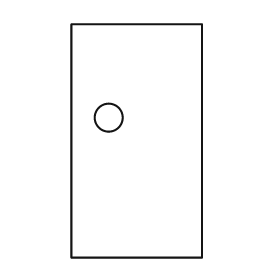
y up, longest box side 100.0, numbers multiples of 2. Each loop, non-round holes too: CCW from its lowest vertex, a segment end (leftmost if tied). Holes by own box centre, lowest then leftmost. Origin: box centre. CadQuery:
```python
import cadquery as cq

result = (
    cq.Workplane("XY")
    .moveTo(-28.0, -50.0)
    .lineTo(28.0, -50.0)
    .lineTo(28.0, 50.0)
    .lineTo(-28.0, 50.0)
    .close()
    .moveTo(-12.0, 10.0)
    .circle(6.0)
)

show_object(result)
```